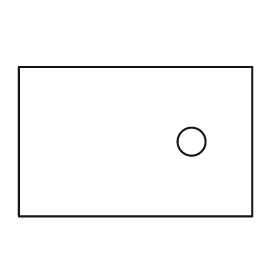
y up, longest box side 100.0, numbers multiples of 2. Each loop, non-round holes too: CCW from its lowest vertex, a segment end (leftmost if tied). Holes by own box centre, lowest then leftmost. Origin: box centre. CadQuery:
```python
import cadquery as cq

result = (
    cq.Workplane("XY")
    .moveTo(-50.0, -32.0)
    .lineTo(50.0, -32.0)
    .lineTo(50.0, 32.0)
    .lineTo(-50.0, 32.0)
    .close()
    .moveTo(24.0, 0.0)
    .circle(6.0)
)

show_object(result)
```